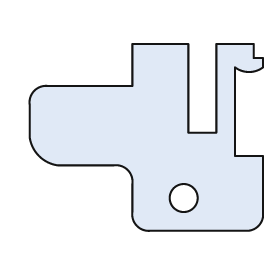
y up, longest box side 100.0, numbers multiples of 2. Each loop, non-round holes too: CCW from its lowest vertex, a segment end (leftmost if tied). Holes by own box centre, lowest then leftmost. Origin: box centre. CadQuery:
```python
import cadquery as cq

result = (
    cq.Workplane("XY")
    .moveTo(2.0, -40.0)
    .lineTo(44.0, -40.0)
    .threePointArc((48.0, -38.0), (50.0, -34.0))
    .lineTo(50.0, -8.0)
    .lineTo(38.0, -8.0)
    .lineTo(38.0, 30.0)
    .threePointArc((44.0, 28.0), (50.0, 30.0))
    .lineTo(50.0, 34.0)
    .lineTo(46.0, 34.0)
    .lineTo(46.0, 40.0)
    .lineTo(30.0, 40.0)
    .lineTo(30.0, 2.0)
    .lineTo(18.0, 2.0)
    .lineTo(18.0, 40.0)
    .lineTo(-6.0, 40.0)
    .lineTo(-6.0, 22.0)
    .lineTo(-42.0, 22.0)
    .threePointArc((-48.0, 20.0), (-50.0, 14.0))
    .lineTo(-50.0, 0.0)
    .threePointArc((-46.0, -8.0), (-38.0, -12.0))
    .lineTo(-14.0, -12.0)
    .threePointArc((-8.0, -14.0), (-6.0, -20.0))
    .lineTo(-6.0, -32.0)
    .threePointArc((-4.0, -38.0), (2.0, -40.0))
    .close()
    .moveTo(16.0, -26.0)
    .circle(6.0)
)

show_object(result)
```